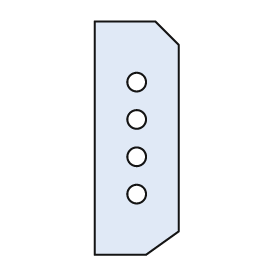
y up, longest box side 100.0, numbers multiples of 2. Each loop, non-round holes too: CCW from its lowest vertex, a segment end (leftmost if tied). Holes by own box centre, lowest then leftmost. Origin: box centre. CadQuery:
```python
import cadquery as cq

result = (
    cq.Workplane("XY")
    .moveTo(-18.0, -50.0)
    .lineTo(4.0, -50.0)
    .lineTo(18.0, -40.0)
    .lineTo(18.0, 40.0)
    .lineTo(8.0, 50.0)
    .lineTo(-18.0, 50.0)
    .close()
    .moveTo(0.0, -24.0)
    .circle(4.0)
    .moveTo(0.0, -8.0)
    .circle(4.0)
    .moveTo(0.0, 8.0)
    .circle(4.0)
    .moveTo(0.0, 24.0)
    .circle(4.0)
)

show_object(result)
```